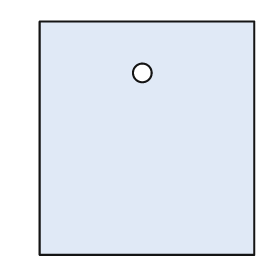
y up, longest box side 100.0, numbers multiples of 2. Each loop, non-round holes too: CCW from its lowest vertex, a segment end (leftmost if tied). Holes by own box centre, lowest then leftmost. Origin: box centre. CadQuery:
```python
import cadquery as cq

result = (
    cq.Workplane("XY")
    .moveTo(-46.0, -50.0)
    .lineTo(46.0, -50.0)
    .lineTo(46.0, 50.0)
    .lineTo(-46.0, 50.0)
    .close()
    .moveTo(-2.0, 28.0)
    .circle(4.0)
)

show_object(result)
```